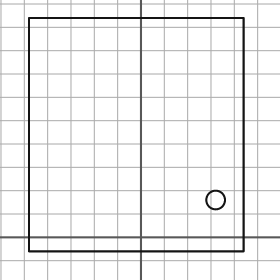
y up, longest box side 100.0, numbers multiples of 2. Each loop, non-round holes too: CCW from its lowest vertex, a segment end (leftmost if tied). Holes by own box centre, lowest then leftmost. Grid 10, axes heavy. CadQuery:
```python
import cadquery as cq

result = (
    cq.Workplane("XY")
    .moveTo(-48.0, -6.0)
    .lineTo(44.0, -6.0)
    .lineTo(44.0, 94.0)
    .lineTo(-48.0, 94.0)
    .close()
    .moveTo(32.0, 16.0)
    .circle(4.0)
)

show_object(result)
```